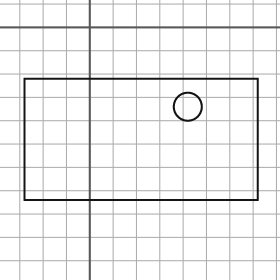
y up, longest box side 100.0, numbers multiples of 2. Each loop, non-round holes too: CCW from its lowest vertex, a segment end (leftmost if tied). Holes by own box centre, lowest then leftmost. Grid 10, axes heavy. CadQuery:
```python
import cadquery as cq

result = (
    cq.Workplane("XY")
    .moveTo(-28.0, -74.0)
    .lineTo(72.0, -74.0)
    .lineTo(72.0, -22.0)
    .lineTo(-28.0, -22.0)
    .close()
    .moveTo(42.0, -34.0)
    .circle(6.0)
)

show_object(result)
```